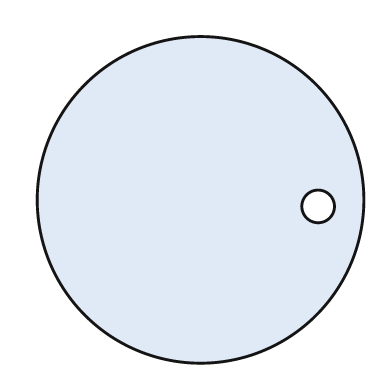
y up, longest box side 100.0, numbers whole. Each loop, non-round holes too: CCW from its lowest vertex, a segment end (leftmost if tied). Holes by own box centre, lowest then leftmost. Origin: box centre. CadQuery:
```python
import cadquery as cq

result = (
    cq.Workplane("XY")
    .moveTo(0.0, 0.0)
    .circle(50.0)
    .moveTo(36.0, -2.0)
    .circle(5.0)
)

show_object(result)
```